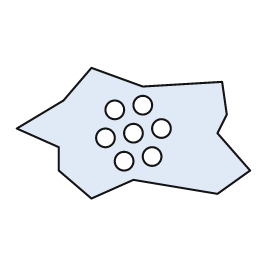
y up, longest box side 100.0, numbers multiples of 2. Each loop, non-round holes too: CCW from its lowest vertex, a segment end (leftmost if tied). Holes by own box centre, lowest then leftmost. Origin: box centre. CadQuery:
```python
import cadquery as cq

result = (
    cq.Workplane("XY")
    .moveTo(-18.0, -28.0)
    .lineTo(0.0, -20.0)
    .lineTo(36.0, -26.0)
    .lineTo(50.0, -16.0)
    .lineTo(36.0, 0.0)
    .lineTo(40.0, 8.0)
    .lineTo(38.0, 22.0)
    .lineTo(4.0, 20.0)
    .lineTo(-18.0, 28.0)
    .lineTo(-30.0, 14.0)
    .lineTo(-50.0, 2.0)
    .lineTo(-32.0, -6.0)
    .lineTo(-32.0, -16.0)
    .close()
    .moveTo(-4.0, -12.0)
    .circle(4.0)
    .moveTo(8.0, -10.0)
    .circle(4.0)
    .moveTo(-12.0, -2.0)
    .circle(4.0)
    .moveTo(0.0, 0.0)
    .circle(4.0)
    .moveTo(12.0, 2.0)
    .circle(4.0)
    .moveTo(-8.0, 10.0)
    .circle(4.0)
    .moveTo(4.0, 12.0)
    .circle(4.0)
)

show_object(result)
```